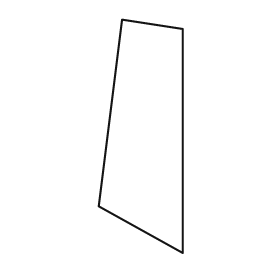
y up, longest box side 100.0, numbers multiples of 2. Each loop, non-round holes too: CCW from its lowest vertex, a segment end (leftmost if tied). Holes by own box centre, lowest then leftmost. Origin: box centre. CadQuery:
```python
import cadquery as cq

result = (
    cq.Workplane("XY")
    .moveTo(18.0, -50.0)
    .lineTo(18.0, 46.0)
    .lineTo(-8.0, 50.0)
    .lineTo(-18.0, -30.0)
    .close()
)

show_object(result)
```